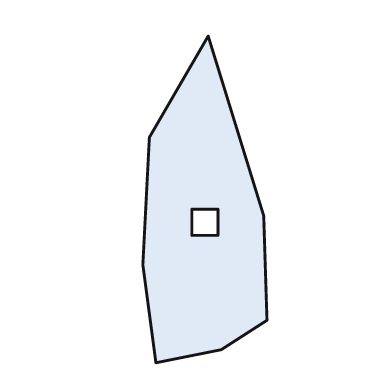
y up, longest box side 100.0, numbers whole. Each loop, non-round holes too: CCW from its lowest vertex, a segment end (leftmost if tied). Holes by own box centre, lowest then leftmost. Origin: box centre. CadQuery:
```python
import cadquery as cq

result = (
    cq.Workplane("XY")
    .moveTo(-15.0, -50.0)
    .lineTo(5.0, -46.0)
    .lineTo(19.0, -37.0)
    .lineTo(18.0, -5.0)
    .lineTo(1.0, 50.0)
    .lineTo(-17.0, 19.0)
    .lineTo(-19.0, -20.0)
    .close()
    .moveTo(-4.0, -11.0)
    .lineTo(4.0, -11.0)
    .lineTo(4.0, -3.0)
    .lineTo(-4.0, -3.0)
    .close()
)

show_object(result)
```